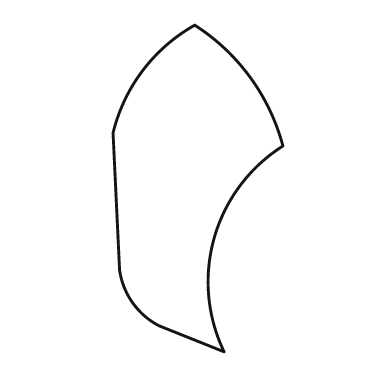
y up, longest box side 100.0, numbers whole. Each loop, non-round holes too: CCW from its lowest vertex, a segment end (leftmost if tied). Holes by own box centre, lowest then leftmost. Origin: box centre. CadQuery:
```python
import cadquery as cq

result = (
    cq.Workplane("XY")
    .moveTo(8.0, -50.0)
    .threePointArc((5.0, -15.0), (26.0, 13.0))
    .threePointArc((16.0, 34.0), (-1.0, 50.0))
    .threePointArc((-17.0, 36.0), (-26.0, 17.0))
    .lineTo(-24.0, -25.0)
    .threePointArc((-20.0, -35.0), (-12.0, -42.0))
    .close()
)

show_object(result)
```